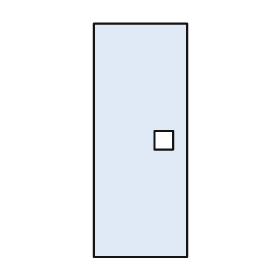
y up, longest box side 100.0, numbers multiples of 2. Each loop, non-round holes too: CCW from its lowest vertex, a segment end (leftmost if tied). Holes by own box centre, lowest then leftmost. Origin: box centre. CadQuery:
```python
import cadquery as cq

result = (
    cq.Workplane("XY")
    .moveTo(-20.0, -50.0)
    .lineTo(20.0, -50.0)
    .lineTo(20.0, 50.0)
    .lineTo(-20.0, 50.0)
    .close()
    .moveTo(6.0, -4.0)
    .lineTo(14.0, -4.0)
    .lineTo(14.0, 4.0)
    .lineTo(6.0, 4.0)
    .close()
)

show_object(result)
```